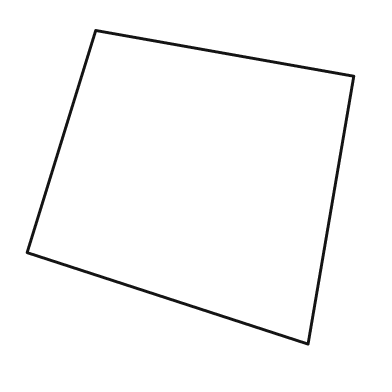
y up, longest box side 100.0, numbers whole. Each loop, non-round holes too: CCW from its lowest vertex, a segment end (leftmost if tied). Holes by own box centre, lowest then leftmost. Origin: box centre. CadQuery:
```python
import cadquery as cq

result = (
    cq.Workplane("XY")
    .moveTo(36.0, -48.0)
    .lineTo(50.0, 34.0)
    .lineTo(-29.0, 48.0)
    .lineTo(-50.0, -20.0)
    .close()
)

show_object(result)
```